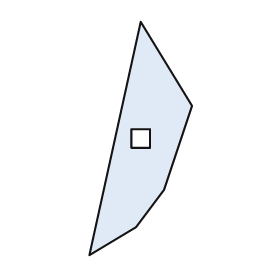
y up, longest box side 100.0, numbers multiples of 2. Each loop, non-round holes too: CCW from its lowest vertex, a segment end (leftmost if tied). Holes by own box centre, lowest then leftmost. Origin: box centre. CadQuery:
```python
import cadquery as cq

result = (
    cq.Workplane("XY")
    .moveTo(-22.0, -50.0)
    .lineTo(-2.0, -38.0)
    .lineTo(10.0, -22.0)
    .lineTo(22.0, 14.0)
    .lineTo(0.0, 50.0)
    .close()
    .moveTo(-4.0, -4.0)
    .lineTo(4.0, -4.0)
    .lineTo(4.0, 4.0)
    .lineTo(-4.0, 4.0)
    .close()
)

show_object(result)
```